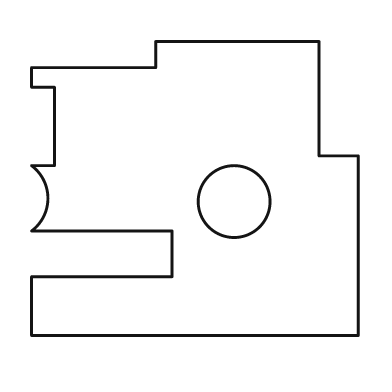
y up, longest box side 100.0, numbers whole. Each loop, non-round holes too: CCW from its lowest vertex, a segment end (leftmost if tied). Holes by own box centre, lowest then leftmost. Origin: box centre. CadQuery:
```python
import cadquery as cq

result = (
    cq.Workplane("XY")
    .moveTo(-50.0, -45.0)
    .lineTo(50.0, -45.0)
    .lineTo(50.0, 10.0)
    .lineTo(38.0, 10.0)
    .lineTo(38.0, 45.0)
    .lineTo(-12.0, 45.0)
    .lineTo(-12.0, 37.0)
    .lineTo(-50.0, 37.0)
    .lineTo(-50.0, 31.0)
    .lineTo(-43.0, 31.0)
    .lineTo(-43.0, 7.0)
    .lineTo(-50.0, 7.0)
    .threePointArc((-45.0, -3.0), (-50.0, -13.0))
    .lineTo(-7.0, -13.0)
    .lineTo(-7.0, -27.0)
    .lineTo(-50.0, -27.0)
    .close()
    .moveTo(12.0, -4.0)
    .circle(11.0)
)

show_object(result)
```